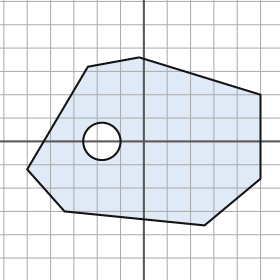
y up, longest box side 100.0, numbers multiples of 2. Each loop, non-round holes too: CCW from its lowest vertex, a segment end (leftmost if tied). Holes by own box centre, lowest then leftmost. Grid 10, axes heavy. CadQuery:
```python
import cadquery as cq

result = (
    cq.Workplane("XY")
    .moveTo(26.0, -36.0)
    .lineTo(50.0, -16.0)
    .lineTo(50.0, 20.0)
    .lineTo(-2.0, 36.0)
    .lineTo(-24.0, 32.0)
    .lineTo(-50.0, -12.0)
    .lineTo(-34.0, -30.0)
    .close()
    .moveTo(-18.0, 0.0)
    .circle(8.0)
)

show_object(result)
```